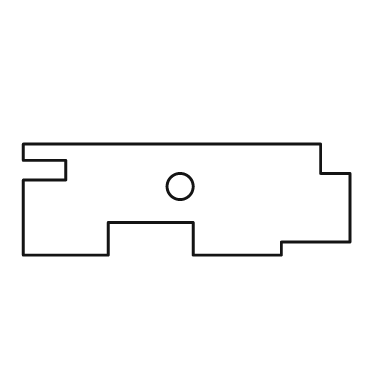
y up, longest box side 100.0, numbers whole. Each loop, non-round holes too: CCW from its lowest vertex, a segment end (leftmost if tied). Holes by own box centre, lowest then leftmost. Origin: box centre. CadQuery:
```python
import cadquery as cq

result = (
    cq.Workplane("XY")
    .moveTo(-50.0, -17.0)
    .lineTo(-24.0, -17.0)
    .lineTo(-24.0, -7.0)
    .lineTo(2.0, -7.0)
    .lineTo(2.0, -17.0)
    .lineTo(29.0, -17.0)
    .lineTo(29.0, -13.0)
    .lineTo(50.0, -13.0)
    .lineTo(50.0, 8.0)
    .lineTo(41.0, 8.0)
    .lineTo(41.0, 17.0)
    .lineTo(-50.0, 17.0)
    .lineTo(-50.0, 12.0)
    .lineTo(-37.0, 12.0)
    .lineTo(-37.0, 6.0)
    .lineTo(-50.0, 6.0)
    .close()
    .moveTo(-2.0, 4.0)
    .circle(4.0)
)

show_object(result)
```